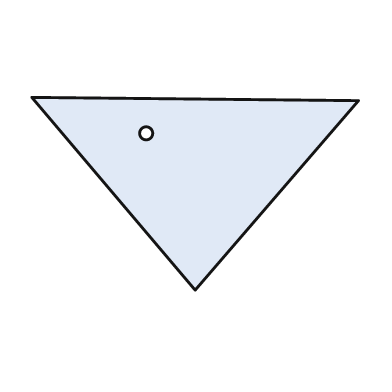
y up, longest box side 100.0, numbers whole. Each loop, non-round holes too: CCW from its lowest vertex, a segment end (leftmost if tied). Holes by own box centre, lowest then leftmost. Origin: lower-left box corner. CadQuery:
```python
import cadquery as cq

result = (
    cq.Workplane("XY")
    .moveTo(50.0, 0.0)
    .lineTo(100.0, 58.0)
    .lineTo(0.0, 59.0)
    .close()
    .moveTo(35.0, 48.0)
    .circle(2.0)
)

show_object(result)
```